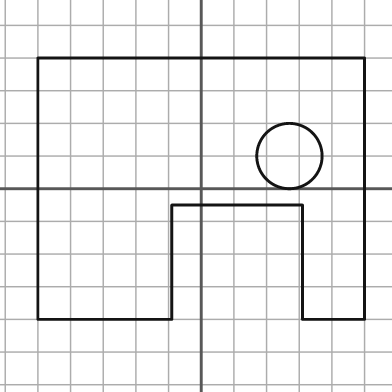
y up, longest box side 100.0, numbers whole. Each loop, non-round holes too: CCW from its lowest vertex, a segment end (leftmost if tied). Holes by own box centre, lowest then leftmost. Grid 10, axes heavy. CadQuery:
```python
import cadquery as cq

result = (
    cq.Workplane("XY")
    .moveTo(-50.0, -40.0)
    .lineTo(-9.0, -40.0)
    .lineTo(-9.0, -5.0)
    .lineTo(31.0, -5.0)
    .lineTo(31.0, -40.0)
    .lineTo(50.0, -40.0)
    .lineTo(50.0, 40.0)
    .lineTo(-50.0, 40.0)
    .close()
    .moveTo(27.0, 10.0)
    .circle(10.0)
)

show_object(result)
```